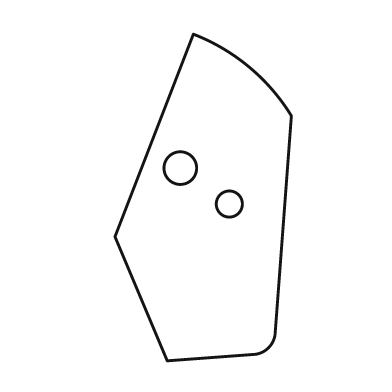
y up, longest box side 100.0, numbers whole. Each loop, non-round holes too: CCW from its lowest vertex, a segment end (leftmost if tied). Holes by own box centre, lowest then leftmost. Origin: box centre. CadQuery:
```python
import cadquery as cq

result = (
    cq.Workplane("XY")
    .moveTo(-11.0, -50.0)
    .lineTo(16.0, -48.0)
    .threePointArc((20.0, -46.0), (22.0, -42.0))
    .lineTo(27.0, 25.0)
    .threePointArc((14.0, 40.0), (-3.0, 50.0))
    .lineTo(-27.0, -12.0)
    .close()
    .moveTo(8.0, -2.0)
    .circle(4.0)
    .moveTo(-7.0, 9.0)
    .circle(5.0)
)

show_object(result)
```